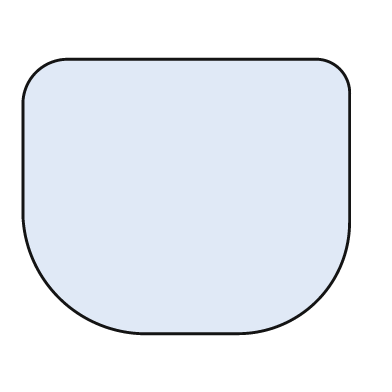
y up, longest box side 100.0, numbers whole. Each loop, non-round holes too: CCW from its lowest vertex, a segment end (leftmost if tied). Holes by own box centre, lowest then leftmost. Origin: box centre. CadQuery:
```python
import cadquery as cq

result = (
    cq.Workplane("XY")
    .moveTo(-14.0, -42.0)
    .lineTo(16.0, -42.0)
    .threePointArc((40.0, -32.0), (50.0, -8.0))
    .lineTo(50.0, 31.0)
    .threePointArc((47.0, 39.0), (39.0, 42.0))
    .lineTo(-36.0, 42.0)
    .threePointArc((-46.0, 38.0), (-50.0, 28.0))
    .lineTo(-50.0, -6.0)
    .threePointArc((-39.0, -31.0), (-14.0, -42.0))
    .close()
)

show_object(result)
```